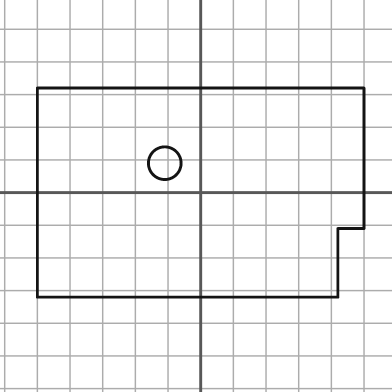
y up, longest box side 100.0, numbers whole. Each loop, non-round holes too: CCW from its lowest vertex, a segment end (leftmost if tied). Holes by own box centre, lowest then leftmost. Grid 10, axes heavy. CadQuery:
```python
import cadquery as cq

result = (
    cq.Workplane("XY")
    .moveTo(-50.0, -32.0)
    .lineTo(42.0, -32.0)
    .lineTo(42.0, -11.0)
    .lineTo(50.0, -11.0)
    .lineTo(50.0, 32.0)
    .lineTo(-50.0, 32.0)
    .close()
    .moveTo(-11.0, 9.0)
    .circle(5.0)
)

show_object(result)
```